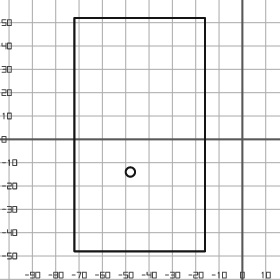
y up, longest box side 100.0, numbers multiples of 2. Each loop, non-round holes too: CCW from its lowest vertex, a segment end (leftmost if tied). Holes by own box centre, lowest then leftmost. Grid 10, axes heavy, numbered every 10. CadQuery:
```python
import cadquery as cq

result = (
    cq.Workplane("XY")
    .moveTo(-72.0, -48.0)
    .lineTo(-16.0, -48.0)
    .lineTo(-16.0, 52.0)
    .lineTo(-72.0, 52.0)
    .close()
    .moveTo(-48.0, -14.0)
    .circle(2.0)
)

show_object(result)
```